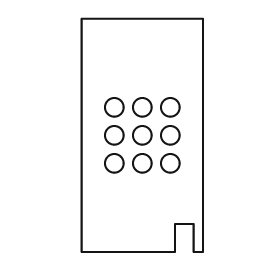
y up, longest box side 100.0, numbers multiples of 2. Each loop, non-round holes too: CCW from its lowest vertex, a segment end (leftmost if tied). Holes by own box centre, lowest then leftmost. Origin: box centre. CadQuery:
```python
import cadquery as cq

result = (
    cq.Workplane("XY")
    .moveTo(-26.0, -50.0)
    .lineTo(14.0, -50.0)
    .lineTo(14.0, -38.0)
    .lineTo(22.0, -38.0)
    .lineTo(22.0, -50.0)
    .lineTo(26.0, -50.0)
    .lineTo(26.0, 50.0)
    .lineTo(-26.0, 50.0)
    .close()
    .moveTo(-12.0, -12.0)
    .circle(4.0)
    .moveTo(0.0, -12.0)
    .circle(4.0)
    .moveTo(12.0, -12.0)
    .circle(4.0)
    .moveTo(-12.0, 0.0)
    .circle(4.0)
    .moveTo(0.0, 0.0)
    .circle(4.0)
    .moveTo(12.0, 0.0)
    .circle(4.0)
    .moveTo(-12.0, 12.0)
    .circle(4.0)
    .moveTo(0.0, 12.0)
    .circle(4.0)
    .moveTo(12.0, 12.0)
    .circle(4.0)
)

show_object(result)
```